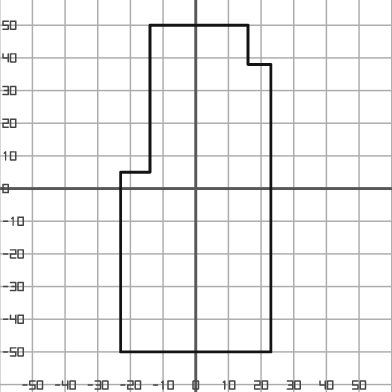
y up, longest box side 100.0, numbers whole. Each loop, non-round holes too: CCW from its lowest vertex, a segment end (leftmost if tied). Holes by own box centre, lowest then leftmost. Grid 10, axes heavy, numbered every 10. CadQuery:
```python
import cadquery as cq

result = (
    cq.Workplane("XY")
    .moveTo(-23.0, -50.0)
    .lineTo(23.0, -50.0)
    .lineTo(23.0, 38.0)
    .lineTo(16.0, 38.0)
    .lineTo(16.0, 50.0)
    .lineTo(-14.0, 50.0)
    .lineTo(-14.0, 5.0)
    .lineTo(-23.0, 5.0)
    .close()
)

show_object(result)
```